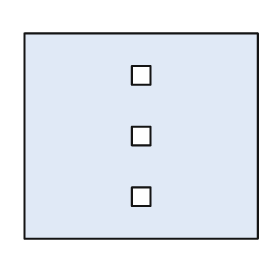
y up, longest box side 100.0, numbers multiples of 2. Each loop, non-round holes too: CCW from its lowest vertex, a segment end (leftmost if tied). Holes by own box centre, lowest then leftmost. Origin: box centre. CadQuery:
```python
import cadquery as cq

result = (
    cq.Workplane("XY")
    .moveTo(-50.0, -44.0)
    .lineTo(50.0, -44.0)
    .lineTo(50.0, 44.0)
    .lineTo(-50.0, 44.0)
    .close()
    .moveTo(-4.0, -30.0)
    .lineTo(4.0, -30.0)
    .lineTo(4.0, -22.0)
    .lineTo(-4.0, -22.0)
    .close()
    .moveTo(-4.0, -4.0)
    .lineTo(4.0, -4.0)
    .lineTo(4.0, 4.0)
    .lineTo(-4.0, 4.0)
    .close()
    .moveTo(-4.0, 22.0)
    .lineTo(4.0, 22.0)
    .lineTo(4.0, 30.0)
    .lineTo(-4.0, 30.0)
    .close()
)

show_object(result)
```